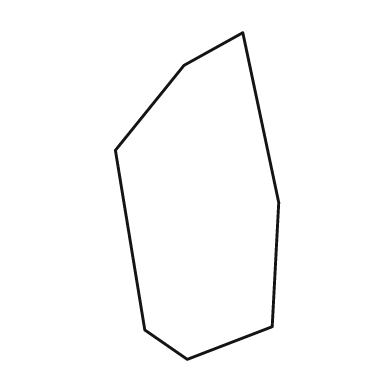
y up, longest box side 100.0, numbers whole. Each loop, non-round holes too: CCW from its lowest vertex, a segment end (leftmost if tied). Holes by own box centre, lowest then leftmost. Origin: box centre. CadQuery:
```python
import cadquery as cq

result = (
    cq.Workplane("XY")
    .moveTo(-3.0, -50.0)
    .lineTo(23.0, -40.0)
    .lineTo(25.0, -2.0)
    .lineTo(14.0, 50.0)
    .lineTo(-4.0, 40.0)
    .lineTo(-25.0, 14.0)
    .lineTo(-16.0, -41.0)
    .close()
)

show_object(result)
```